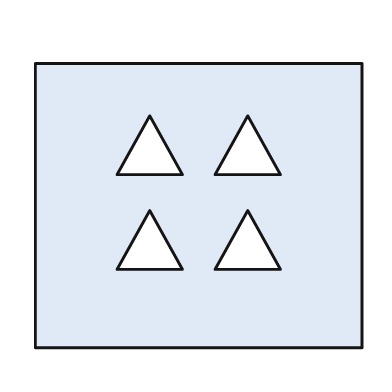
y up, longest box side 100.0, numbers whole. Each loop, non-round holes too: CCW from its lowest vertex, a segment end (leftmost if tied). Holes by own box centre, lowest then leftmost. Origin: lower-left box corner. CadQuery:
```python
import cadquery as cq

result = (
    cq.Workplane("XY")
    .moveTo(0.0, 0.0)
    .lineTo(100.0, 0.0)
    .lineTo(100.0, 87.0)
    .lineTo(0.0, 87.0)
    .close()
    .moveTo(25.0, 24.0)
    .lineTo(45.0, 24.0)
    .lineTo(35.0, 42.0)
    .close()
    .moveTo(55.0, 24.0)
    .lineTo(75.0, 24.0)
    .lineTo(65.0, 42.0)
    .close()
    .moveTo(25.0, 53.0)
    .lineTo(45.0, 53.0)
    .lineTo(35.0, 71.0)
    .close()
    .moveTo(55.0, 53.0)
    .lineTo(75.0, 53.0)
    .lineTo(65.0, 71.0)
    .close()
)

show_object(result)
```